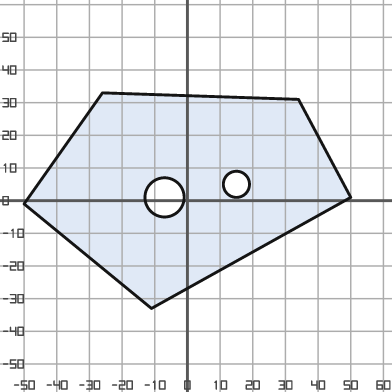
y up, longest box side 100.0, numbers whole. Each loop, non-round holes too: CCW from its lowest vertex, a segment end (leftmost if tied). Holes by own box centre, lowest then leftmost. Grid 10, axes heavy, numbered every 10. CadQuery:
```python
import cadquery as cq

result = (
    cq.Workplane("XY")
    .moveTo(-11.0, -33.0)
    .lineTo(50.0, 1.0)
    .lineTo(34.0, 31.0)
    .lineTo(-26.0, 33.0)
    .lineTo(-50.0, -1.0)
    .close()
    .moveTo(-7.0, 1.0)
    .circle(6.0)
    .moveTo(15.0, 5.0)
    .circle(4.0)
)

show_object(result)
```